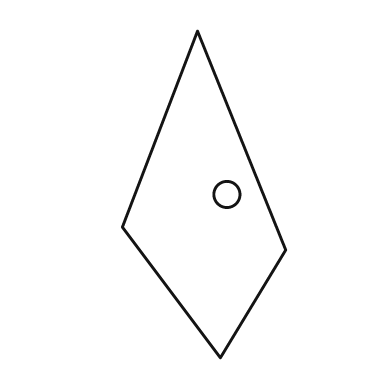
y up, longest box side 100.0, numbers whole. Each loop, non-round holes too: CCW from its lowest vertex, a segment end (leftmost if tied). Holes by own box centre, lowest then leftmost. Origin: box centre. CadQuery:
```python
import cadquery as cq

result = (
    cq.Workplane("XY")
    .moveTo(5.0, -50.0)
    .lineTo(25.0, -17.0)
    .lineTo(-2.0, 50.0)
    .lineTo(-25.0, -10.0)
    .close()
    .moveTo(7.0, 0.0)
    .circle(4.0)
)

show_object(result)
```